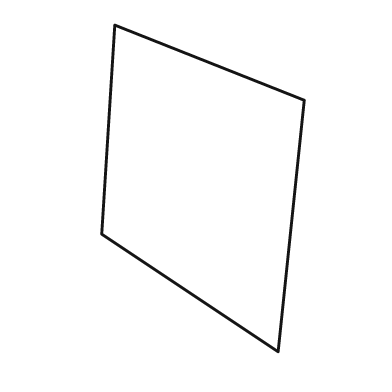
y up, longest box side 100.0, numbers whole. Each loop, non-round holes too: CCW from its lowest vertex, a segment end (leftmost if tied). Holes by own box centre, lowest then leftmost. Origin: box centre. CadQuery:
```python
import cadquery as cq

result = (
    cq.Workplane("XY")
    .moveTo(23.0, -50.0)
    .lineTo(31.0, 27.0)
    .lineTo(-27.0, 50.0)
    .lineTo(-31.0, -14.0)
    .close()
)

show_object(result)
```